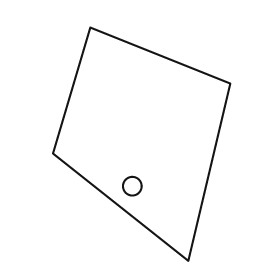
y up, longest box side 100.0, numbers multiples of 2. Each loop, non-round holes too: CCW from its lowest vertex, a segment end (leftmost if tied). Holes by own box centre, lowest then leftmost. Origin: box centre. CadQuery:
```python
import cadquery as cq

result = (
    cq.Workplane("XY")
    .moveTo(20.0, -50.0)
    .lineTo(38.0, 26.0)
    .lineTo(-22.0, 50.0)
    .lineTo(-38.0, -4.0)
    .close()
    .moveTo(-4.0, -18.0)
    .circle(4.0)
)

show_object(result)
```